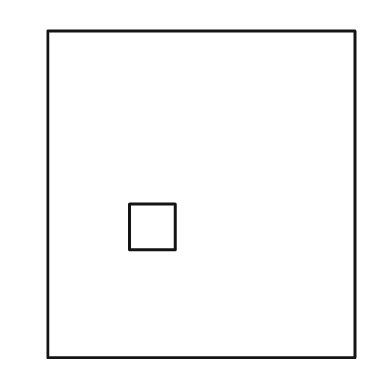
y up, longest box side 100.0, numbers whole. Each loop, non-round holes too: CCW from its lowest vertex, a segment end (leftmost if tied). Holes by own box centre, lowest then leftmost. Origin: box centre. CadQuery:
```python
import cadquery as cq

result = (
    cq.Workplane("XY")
    .moveTo(-47.0, -50.0)
    .lineTo(47.0, -50.0)
    .lineTo(47.0, 50.0)
    .lineTo(-47.0, 50.0)
    .close()
    .moveTo(-22.0, -17.0)
    .lineTo(-8.0, -17.0)
    .lineTo(-8.0, -3.0)
    .lineTo(-22.0, -3.0)
    .close()
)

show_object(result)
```